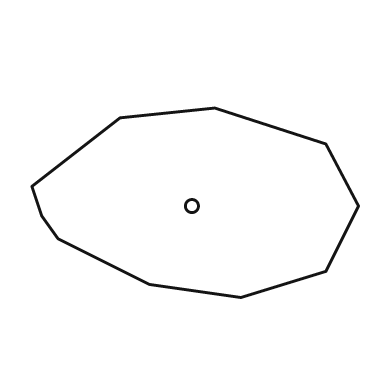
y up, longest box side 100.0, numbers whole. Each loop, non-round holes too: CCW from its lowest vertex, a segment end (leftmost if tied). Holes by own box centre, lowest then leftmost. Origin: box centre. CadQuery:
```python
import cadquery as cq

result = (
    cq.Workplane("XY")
    .moveTo(14.0, -29.0)
    .lineTo(40.0, -21.0)
    .lineTo(50.0, -1.0)
    .lineTo(40.0, 18.0)
    .lineTo(6.0, 29.0)
    .lineTo(-23.0, 26.0)
    .lineTo(-50.0, 5.0)
    .lineTo(-47.0, -4.0)
    .lineTo(-42.0, -11.0)
    .lineTo(-14.0, -25.0)
    .close()
    .moveTo(-1.0, -1.0)
    .circle(2.0)
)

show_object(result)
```